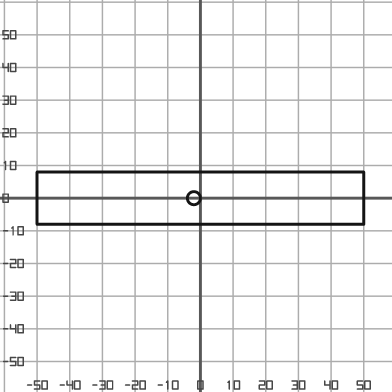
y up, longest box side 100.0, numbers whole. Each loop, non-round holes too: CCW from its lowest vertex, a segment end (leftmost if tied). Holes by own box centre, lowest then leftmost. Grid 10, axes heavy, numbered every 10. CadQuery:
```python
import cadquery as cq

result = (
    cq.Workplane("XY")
    .moveTo(-50.0, -8.0)
    .lineTo(50.0, -8.0)
    .lineTo(50.0, 8.0)
    .lineTo(-50.0, 8.0)
    .close()
    .moveTo(-2.0, 0.0)
    .circle(2.0)
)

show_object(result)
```